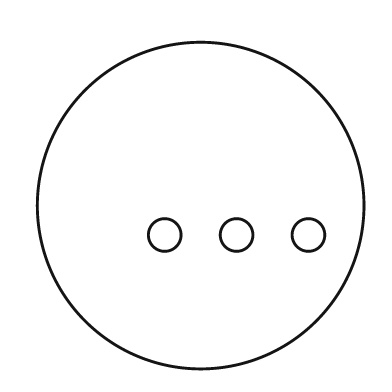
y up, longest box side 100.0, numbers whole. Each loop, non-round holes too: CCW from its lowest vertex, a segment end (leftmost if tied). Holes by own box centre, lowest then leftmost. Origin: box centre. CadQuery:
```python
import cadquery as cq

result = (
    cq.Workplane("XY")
    .moveTo(0.0, 0.0)
    .circle(50.0)
    .moveTo(-11.0, -9.0)
    .circle(5.0)
    .moveTo(11.0, -9.0)
    .circle(5.0)
    .moveTo(33.0, -9.0)
    .circle(5.0)
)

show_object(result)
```